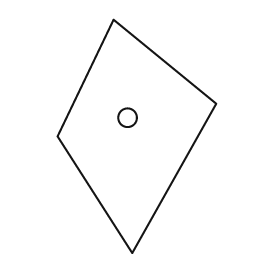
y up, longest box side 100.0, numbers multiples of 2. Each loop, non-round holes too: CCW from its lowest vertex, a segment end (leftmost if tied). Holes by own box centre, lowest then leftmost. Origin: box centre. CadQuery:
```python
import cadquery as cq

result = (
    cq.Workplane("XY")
    .moveTo(-2.0, -50.0)
    .lineTo(34.0, 14.0)
    .lineTo(-10.0, 50.0)
    .lineTo(-34.0, 0.0)
    .close()
    .moveTo(-4.0, 8.0)
    .circle(4.0)
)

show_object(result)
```